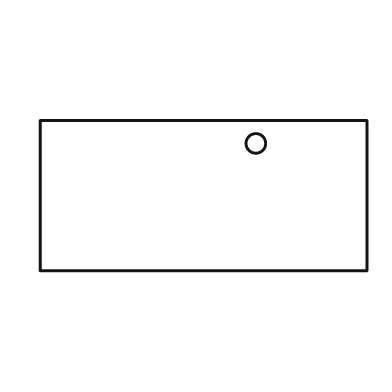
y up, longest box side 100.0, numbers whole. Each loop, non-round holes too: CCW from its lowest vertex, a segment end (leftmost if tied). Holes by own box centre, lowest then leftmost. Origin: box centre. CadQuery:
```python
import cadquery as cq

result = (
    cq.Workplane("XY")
    .moveTo(-50.0, -23.0)
    .lineTo(50.0, -23.0)
    .lineTo(50.0, 23.0)
    .lineTo(-50.0, 23.0)
    .close()
    .moveTo(16.0, 16.0)
    .circle(3.0)
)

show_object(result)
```